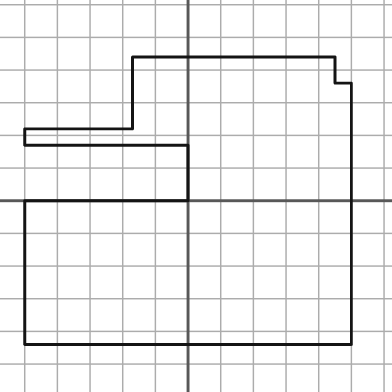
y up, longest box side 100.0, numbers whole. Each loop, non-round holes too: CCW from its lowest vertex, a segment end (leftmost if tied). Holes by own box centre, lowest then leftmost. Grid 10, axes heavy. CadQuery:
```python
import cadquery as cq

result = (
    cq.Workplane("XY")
    .moveTo(-50.0, -44.0)
    .lineTo(50.0, -44.0)
    .lineTo(50.0, 36.0)
    .lineTo(45.0, 36.0)
    .lineTo(45.0, 44.0)
    .lineTo(-17.0, 44.0)
    .lineTo(-17.0, 22.0)
    .lineTo(-50.0, 22.0)
    .lineTo(-50.0, 17.0)
    .lineTo(0.0, 17.0)
    .lineTo(0.0, 0.0)
    .lineTo(-50.0, 0.0)
    .close()
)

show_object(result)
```